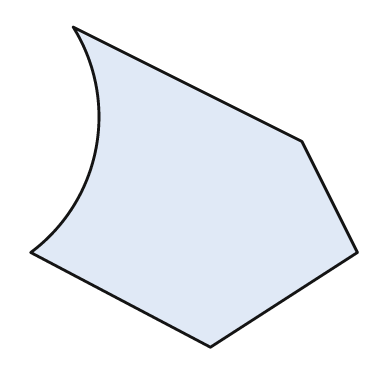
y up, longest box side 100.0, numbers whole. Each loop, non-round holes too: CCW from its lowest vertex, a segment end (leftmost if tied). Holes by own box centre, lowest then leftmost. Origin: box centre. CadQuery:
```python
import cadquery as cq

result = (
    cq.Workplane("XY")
    .moveTo(5.0, -49.0)
    .lineTo(50.0, -20.0)
    .lineTo(33.0, 14.0)
    .lineTo(-37.0, 49.0)
    .threePointArc((-30.0, 12.0), (-50.0, -20.0))
    .close()
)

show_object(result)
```